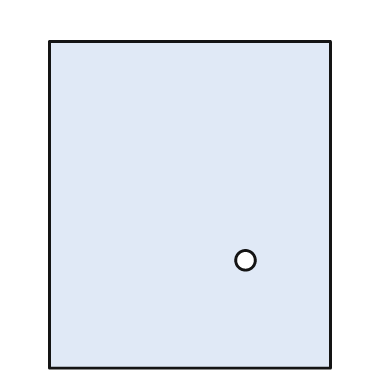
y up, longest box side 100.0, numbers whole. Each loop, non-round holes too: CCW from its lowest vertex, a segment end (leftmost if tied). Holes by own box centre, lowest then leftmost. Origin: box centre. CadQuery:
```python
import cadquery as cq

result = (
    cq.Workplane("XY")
    .moveTo(-43.0, -50.0)
    .lineTo(43.0, -50.0)
    .lineTo(43.0, 50.0)
    .lineTo(-43.0, 50.0)
    .close()
    .moveTo(17.0, -17.0)
    .circle(3.0)
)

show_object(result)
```